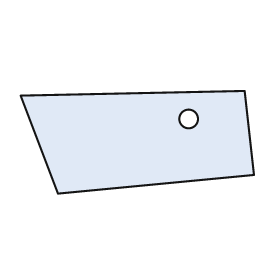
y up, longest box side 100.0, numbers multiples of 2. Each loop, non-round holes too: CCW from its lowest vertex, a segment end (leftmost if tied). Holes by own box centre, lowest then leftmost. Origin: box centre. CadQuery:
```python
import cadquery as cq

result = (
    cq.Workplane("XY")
    .moveTo(-34.0, -22.0)
    .lineTo(50.0, -14.0)
    .lineTo(46.0, 22.0)
    .lineTo(-50.0, 20.0)
    .close()
    .moveTo(22.0, 10.0)
    .circle(4.0)
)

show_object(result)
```